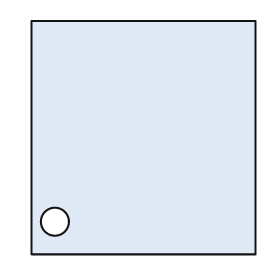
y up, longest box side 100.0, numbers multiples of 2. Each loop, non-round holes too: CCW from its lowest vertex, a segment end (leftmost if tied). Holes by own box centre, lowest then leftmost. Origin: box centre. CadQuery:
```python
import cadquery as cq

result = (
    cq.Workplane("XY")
    .moveTo(-48.0, -50.0)
    .lineTo(48.0, -50.0)
    .lineTo(48.0, 50.0)
    .lineTo(-48.0, 50.0)
    .close()
    .moveTo(-38.0, -36.0)
    .circle(6.0)
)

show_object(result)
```